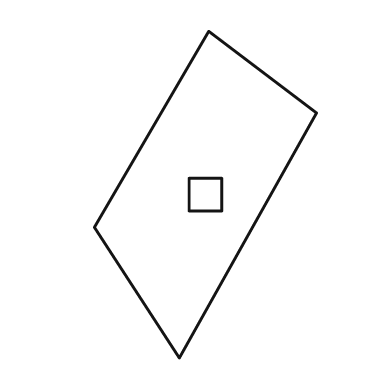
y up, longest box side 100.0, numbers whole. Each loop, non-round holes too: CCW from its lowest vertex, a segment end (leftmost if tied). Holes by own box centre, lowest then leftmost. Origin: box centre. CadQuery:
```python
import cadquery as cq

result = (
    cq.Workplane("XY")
    .moveTo(-8.0, -50.0)
    .lineTo(34.0, 25.0)
    .lineTo(1.0, 50.0)
    .lineTo(-34.0, -10.0)
    .close()
    .moveTo(-5.0, -5.0)
    .lineTo(5.0, -5.0)
    .lineTo(5.0, 5.0)
    .lineTo(-5.0, 5.0)
    .close()
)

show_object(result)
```